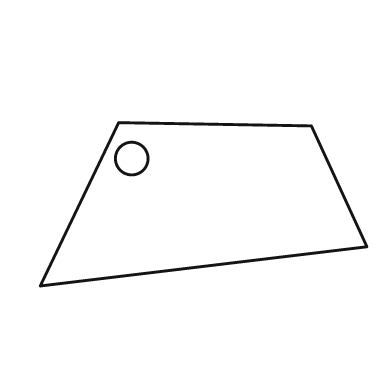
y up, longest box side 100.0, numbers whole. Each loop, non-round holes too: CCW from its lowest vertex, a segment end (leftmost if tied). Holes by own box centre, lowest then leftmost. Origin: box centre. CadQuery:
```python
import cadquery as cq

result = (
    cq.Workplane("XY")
    .moveTo(-50.0, -25.0)
    .lineTo(50.0, -13.0)
    .lineTo(33.0, 24.0)
    .lineTo(-26.0, 25.0)
    .close()
    .moveTo(-22.0, 14.0)
    .circle(5.0)
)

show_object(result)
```